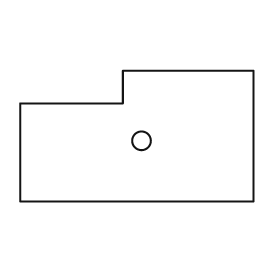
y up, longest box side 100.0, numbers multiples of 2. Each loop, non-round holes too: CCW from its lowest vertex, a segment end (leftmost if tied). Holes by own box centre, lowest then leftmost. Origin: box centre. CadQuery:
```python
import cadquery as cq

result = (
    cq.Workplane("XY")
    .moveTo(-50.0, -28.0)
    .lineTo(50.0, -28.0)
    .lineTo(50.0, 28.0)
    .lineTo(-6.0, 28.0)
    .lineTo(-6.0, 14.0)
    .lineTo(-50.0, 14.0)
    .close()
    .moveTo(2.0, -2.0)
    .circle(4.0)
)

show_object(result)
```